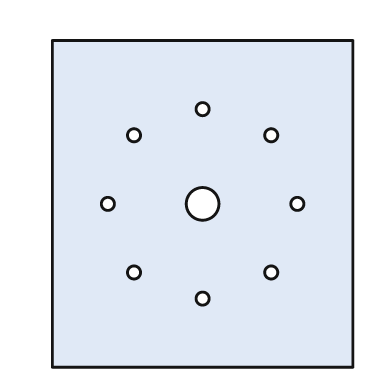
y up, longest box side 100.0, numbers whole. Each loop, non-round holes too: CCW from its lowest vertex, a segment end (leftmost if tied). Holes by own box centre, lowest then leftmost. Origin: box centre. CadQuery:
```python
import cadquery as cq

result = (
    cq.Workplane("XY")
    .moveTo(-46.0, -50.0)
    .lineTo(46.0, -50.0)
    .lineTo(46.0, 50.0)
    .lineTo(-46.0, 50.0)
    .close()
    .moveTo(0.0, -29.0)
    .circle(2.0)
    .moveTo(-21.0, -21.0)
    .circle(2.0)
    .moveTo(21.0, -21.0)
    .circle(2.0)
    .moveTo(-29.0, 0.0)
    .circle(2.0)
    .moveTo(0.0, 0.0)
    .circle(5.0)
    .moveTo(29.0, 0.0)
    .circle(2.0)
    .moveTo(-21.0, 21.0)
    .circle(2.0)
    .moveTo(21.0, 21.0)
    .circle(2.0)
    .moveTo(0.0, 29.0)
    .circle(2.0)
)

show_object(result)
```